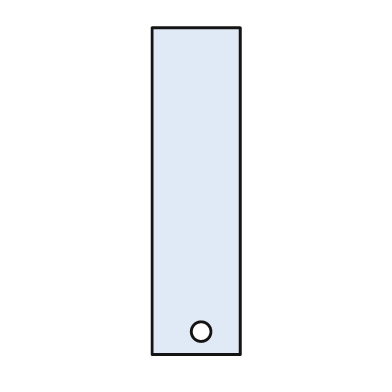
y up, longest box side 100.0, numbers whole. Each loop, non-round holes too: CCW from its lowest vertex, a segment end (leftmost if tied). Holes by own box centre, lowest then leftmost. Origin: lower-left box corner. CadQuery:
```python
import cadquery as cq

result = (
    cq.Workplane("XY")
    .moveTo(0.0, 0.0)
    .lineTo(27.0, 0.0)
    .lineTo(27.0, 100.0)
    .lineTo(0.0, 100.0)
    .close()
    .moveTo(15.0, 7.0)
    .circle(3.0)
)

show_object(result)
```